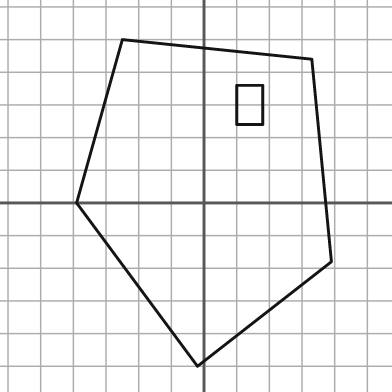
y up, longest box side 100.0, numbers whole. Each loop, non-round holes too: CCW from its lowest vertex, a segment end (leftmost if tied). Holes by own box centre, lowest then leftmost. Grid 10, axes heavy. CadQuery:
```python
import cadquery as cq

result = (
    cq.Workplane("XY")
    .moveTo(-2.0, -50.0)
    .lineTo(39.0, -18.0)
    .lineTo(33.0, 44.0)
    .lineTo(-25.0, 50.0)
    .lineTo(-39.0, 0.0)
    .close()
    .moveTo(10.0, 24.0)
    .lineTo(18.0, 24.0)
    .lineTo(18.0, 36.0)
    .lineTo(10.0, 36.0)
    .close()
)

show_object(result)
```